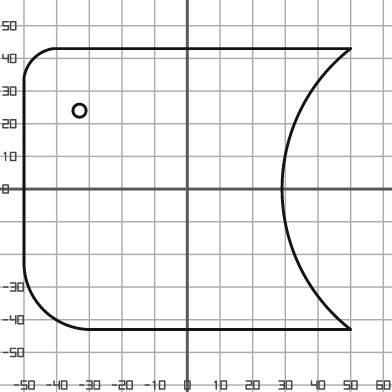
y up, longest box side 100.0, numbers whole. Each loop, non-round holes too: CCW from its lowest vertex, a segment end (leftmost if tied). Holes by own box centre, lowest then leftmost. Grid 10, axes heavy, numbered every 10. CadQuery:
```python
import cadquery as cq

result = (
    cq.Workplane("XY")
    .moveTo(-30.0, -43.0)
    .lineTo(50.0, -43.0)
    .threePointArc((29.0, 0.0), (50.0, 43.0))
    .lineTo(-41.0, 43.0)
    .threePointArc((-47.0, 40.0), (-50.0, 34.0))
    .lineTo(-50.0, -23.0)
    .threePointArc((-44.0, -37.0), (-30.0, -43.0))
    .close()
    .moveTo(-33.0, 24.0)
    .circle(2.0)
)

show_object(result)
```